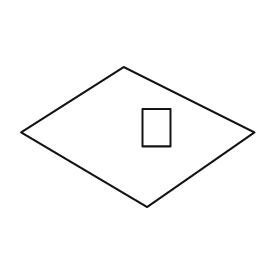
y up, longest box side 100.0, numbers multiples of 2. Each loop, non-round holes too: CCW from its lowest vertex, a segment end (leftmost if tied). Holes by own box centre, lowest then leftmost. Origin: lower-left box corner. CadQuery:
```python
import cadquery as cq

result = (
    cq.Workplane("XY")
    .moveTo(54.0, 0.0)
    .lineTo(100.0, 32.0)
    .lineTo(44.0, 60.0)
    .lineTo(0.0, 32.0)
    .close()
    .moveTo(52.0, 26.0)
    .lineTo(64.0, 26.0)
    .lineTo(64.0, 42.0)
    .lineTo(52.0, 42.0)
    .close()
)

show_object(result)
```